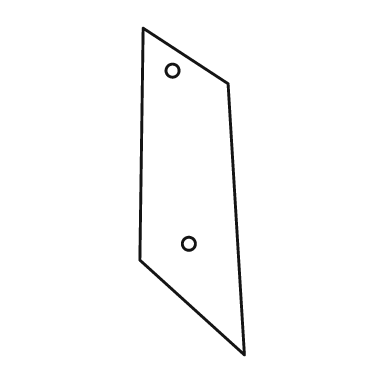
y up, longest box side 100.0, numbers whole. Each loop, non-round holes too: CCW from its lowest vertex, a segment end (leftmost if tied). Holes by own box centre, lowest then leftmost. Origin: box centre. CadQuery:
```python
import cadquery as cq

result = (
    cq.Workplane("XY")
    .moveTo(16.0, -50.0)
    .lineTo(11.0, 33.0)
    .lineTo(-15.0, 50.0)
    .lineTo(-16.0, -21.0)
    .close()
    .moveTo(-1.0, -16.0)
    .circle(2.0)
    .moveTo(-6.0, 37.0)
    .circle(2.0)
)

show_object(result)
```